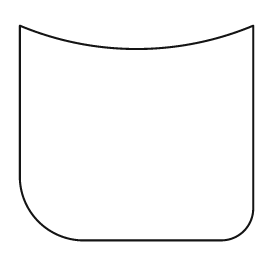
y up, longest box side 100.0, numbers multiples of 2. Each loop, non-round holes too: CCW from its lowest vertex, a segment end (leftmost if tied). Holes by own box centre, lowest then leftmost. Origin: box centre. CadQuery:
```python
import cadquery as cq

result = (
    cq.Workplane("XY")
    .moveTo(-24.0, -46.0)
    .lineTo(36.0, -46.0)
    .threePointArc((46.0, -42.0), (50.0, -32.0))
    .lineTo(50.0, 46.0)
    .threePointArc((0.0, 36.0), (-50.0, 46.0))
    .lineTo(-50.0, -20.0)
    .threePointArc((-42.0, -38.0), (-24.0, -46.0))
    .close()
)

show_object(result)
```